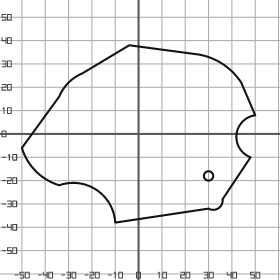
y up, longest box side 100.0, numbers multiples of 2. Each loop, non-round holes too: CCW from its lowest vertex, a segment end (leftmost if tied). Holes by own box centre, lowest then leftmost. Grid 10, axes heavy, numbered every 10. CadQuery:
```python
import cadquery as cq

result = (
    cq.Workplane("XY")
    .moveTo(-10.0, -38.0)
    .lineTo(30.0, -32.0)
    .threePointArc((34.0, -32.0), (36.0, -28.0))
    .lineTo(48.0, -10.0)
    .threePointArc((42.0, 0.0), (50.0, 8.0))
    .lineTo(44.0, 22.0)
    .threePointArc((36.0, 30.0), (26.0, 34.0))
    .lineTo(-4.0, 38.0)
    .lineTo(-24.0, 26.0)
    .threePointArc((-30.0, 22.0), (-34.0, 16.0))
    .lineTo(-50.0, -6.0)
    .threePointArc((-44.0, -16.0), (-34.0, -22.0))
    .threePointArc((-18.0, -24.0), (-10.0, -38.0))
    .close()
    .moveTo(30.0, -18.0)
    .circle(2.0)
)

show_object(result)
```